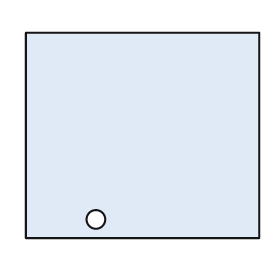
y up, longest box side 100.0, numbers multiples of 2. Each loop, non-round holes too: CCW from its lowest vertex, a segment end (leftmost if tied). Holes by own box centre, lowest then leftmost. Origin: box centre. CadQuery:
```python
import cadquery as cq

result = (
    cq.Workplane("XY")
    .moveTo(-50.0, -44.0)
    .lineTo(50.0, -44.0)
    .lineTo(50.0, 44.0)
    .lineTo(-50.0, 44.0)
    .close()
    .moveTo(-20.0, -36.0)
    .circle(4.0)
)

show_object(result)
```